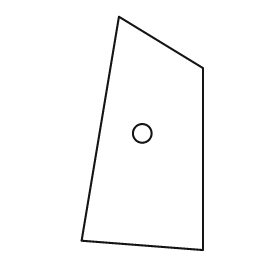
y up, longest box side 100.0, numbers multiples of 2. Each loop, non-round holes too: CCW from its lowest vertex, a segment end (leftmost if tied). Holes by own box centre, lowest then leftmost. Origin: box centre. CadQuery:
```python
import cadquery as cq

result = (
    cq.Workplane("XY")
    .moveTo(26.0, -50.0)
    .lineTo(26.0, 28.0)
    .lineTo(-10.0, 50.0)
    .lineTo(-26.0, -46.0)
    .close()
    .moveTo(0.0, 0.0)
    .circle(4.0)
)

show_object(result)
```